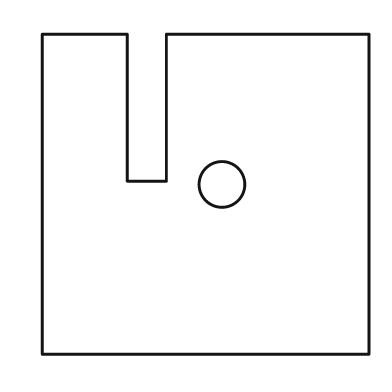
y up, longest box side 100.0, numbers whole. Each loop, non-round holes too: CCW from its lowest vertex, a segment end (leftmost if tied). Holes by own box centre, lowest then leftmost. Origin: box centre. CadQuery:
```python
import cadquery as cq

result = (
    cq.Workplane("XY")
    .moveTo(-50.0, -49.0)
    .lineTo(50.0, -49.0)
    .lineTo(50.0, 49.0)
    .lineTo(-12.0, 49.0)
    .lineTo(-12.0, 4.0)
    .lineTo(-24.0, 4.0)
    .lineTo(-24.0, 49.0)
    .lineTo(-50.0, 49.0)
    .close()
    .moveTo(5.0, 3.0)
    .circle(7.0)
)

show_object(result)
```